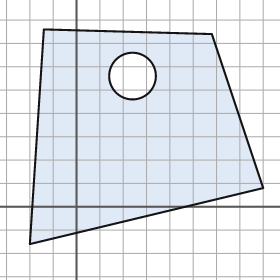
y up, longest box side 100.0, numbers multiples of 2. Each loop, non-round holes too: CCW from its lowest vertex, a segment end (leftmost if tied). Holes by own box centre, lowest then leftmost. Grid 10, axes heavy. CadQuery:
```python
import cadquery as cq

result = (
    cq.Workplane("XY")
    .moveTo(-20.0, -16.0)
    .lineTo(80.0, 8.0)
    .lineTo(58.0, 74.0)
    .lineTo(-14.0, 76.0)
    .close()
    .moveTo(24.0, 56.0)
    .circle(10.0)
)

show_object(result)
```